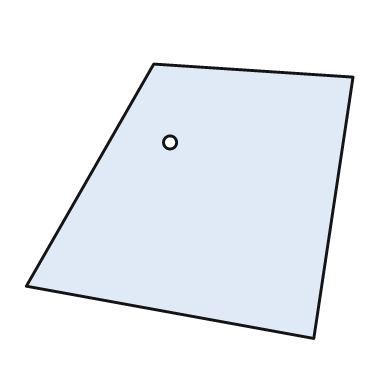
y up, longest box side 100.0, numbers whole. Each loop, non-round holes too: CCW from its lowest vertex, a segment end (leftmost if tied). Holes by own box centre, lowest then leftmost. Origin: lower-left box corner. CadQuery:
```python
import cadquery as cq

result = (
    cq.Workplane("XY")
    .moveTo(88.0, 0.0)
    .lineTo(100.0, 80.0)
    .lineTo(39.0, 84.0)
    .lineTo(0.0, 16.0)
    .close()
    .moveTo(44.0, 60.0)
    .circle(2.0)
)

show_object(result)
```